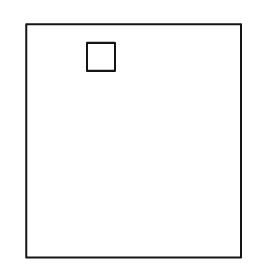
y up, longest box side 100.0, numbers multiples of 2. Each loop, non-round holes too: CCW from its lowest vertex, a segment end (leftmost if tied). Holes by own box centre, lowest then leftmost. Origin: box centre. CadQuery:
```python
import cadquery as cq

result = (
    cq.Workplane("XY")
    .moveTo(-46.0, -50.0)
    .lineTo(46.0, -50.0)
    .lineTo(46.0, 50.0)
    .lineTo(-46.0, 50.0)
    .close()
    .moveTo(-20.0, 30.0)
    .lineTo(-8.0, 30.0)
    .lineTo(-8.0, 42.0)
    .lineTo(-20.0, 42.0)
    .close()
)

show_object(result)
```